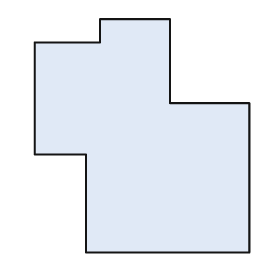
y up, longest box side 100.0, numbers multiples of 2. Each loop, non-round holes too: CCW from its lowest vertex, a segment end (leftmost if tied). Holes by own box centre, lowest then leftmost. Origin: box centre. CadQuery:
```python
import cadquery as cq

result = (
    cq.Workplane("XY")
    .moveTo(-24.0, -50.0)
    .lineTo(46.0, -50.0)
    .lineTo(46.0, 14.0)
    .lineTo(12.0, 14.0)
    .lineTo(12.0, 50.0)
    .lineTo(-18.0, 50.0)
    .lineTo(-18.0, 40.0)
    .lineTo(-46.0, 40.0)
    .lineTo(-46.0, -8.0)
    .lineTo(-24.0, -8.0)
    .close()
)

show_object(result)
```